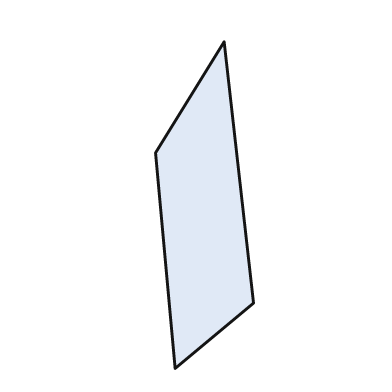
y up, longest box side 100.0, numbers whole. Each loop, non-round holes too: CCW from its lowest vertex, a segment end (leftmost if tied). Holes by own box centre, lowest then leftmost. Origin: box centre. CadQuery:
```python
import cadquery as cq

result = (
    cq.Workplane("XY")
    .moveTo(-9.0, -50.0)
    .lineTo(15.0, -30.0)
    .lineTo(6.0, 50.0)
    .lineTo(-15.0, 16.0)
    .close()
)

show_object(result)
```